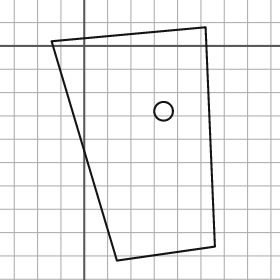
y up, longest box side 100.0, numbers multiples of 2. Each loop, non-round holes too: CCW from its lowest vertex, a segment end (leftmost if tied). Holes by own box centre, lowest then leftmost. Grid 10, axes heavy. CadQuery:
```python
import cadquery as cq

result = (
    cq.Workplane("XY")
    .moveTo(14.0, -92.0)
    .lineTo(56.0, -86.0)
    .lineTo(52.0, 8.0)
    .lineTo(-14.0, 2.0)
    .close()
    .moveTo(34.0, -28.0)
    .circle(4.0)
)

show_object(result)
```